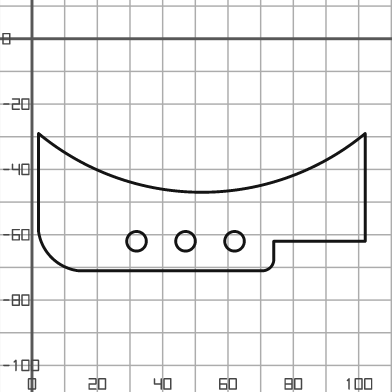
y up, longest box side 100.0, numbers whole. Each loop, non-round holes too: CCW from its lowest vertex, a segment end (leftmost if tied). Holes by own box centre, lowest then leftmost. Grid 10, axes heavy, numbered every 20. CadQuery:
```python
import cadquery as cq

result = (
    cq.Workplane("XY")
    .moveTo(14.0, -71.0)
    .lineTo(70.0, -71.0)
    .threePointArc((73.0, -70.0), (74.0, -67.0))
    .lineTo(74.0, -62.0)
    .lineTo(102.0, -62.0)
    .lineTo(102.0, -29.0)
    .threePointArc((52.0, -47.0), (2.0, -29.0))
    .lineTo(2.0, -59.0)
    .threePointArc((6.0, -67.0), (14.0, -71.0))
    .close()
    .moveTo(32.0, -62.0)
    .circle(3.0)
    .moveTo(47.0, -62.0)
    .circle(3.0)
    .moveTo(62.0, -62.0)
    .circle(3.0)
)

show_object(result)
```